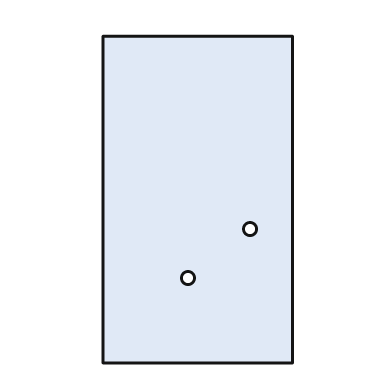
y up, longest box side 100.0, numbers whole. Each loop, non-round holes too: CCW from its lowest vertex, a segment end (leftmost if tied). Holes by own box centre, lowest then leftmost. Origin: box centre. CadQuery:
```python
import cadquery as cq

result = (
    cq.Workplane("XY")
    .moveTo(-29.0, -50.0)
    .lineTo(29.0, -50.0)
    .lineTo(29.0, 50.0)
    .lineTo(-29.0, 50.0)
    .close()
    .moveTo(-3.0, -24.0)
    .circle(2.0)
    .moveTo(16.0, -9.0)
    .circle(2.0)
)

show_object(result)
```